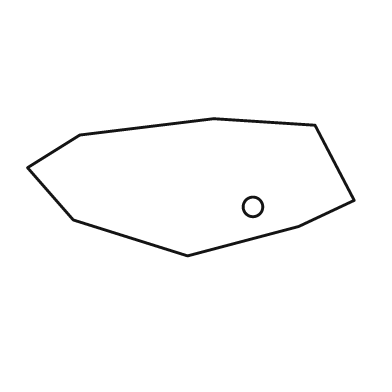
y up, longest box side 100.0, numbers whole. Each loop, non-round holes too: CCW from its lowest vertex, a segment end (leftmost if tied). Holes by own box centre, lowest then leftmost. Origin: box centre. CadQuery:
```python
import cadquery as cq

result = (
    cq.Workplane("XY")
    .moveTo(-1.0, -21.0)
    .lineTo(33.0, -12.0)
    .lineTo(50.0, -4.0)
    .lineTo(38.0, 19.0)
    .lineTo(7.0, 21.0)
    .lineTo(-34.0, 16.0)
    .lineTo(-50.0, 6.0)
    .lineTo(-36.0, -10.0)
    .close()
    .moveTo(19.0, -6.0)
    .circle(3.0)
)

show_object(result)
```